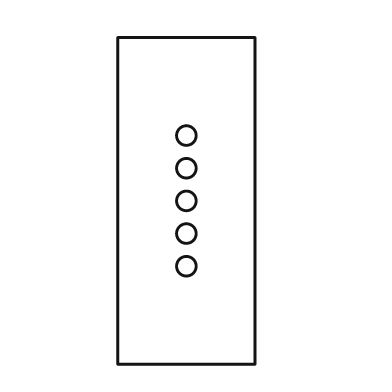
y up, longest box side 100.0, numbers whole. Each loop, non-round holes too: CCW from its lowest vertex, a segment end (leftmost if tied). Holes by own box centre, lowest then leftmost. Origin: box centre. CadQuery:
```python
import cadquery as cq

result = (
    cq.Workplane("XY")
    .moveTo(-21.0, -50.0)
    .lineTo(21.0, -50.0)
    .lineTo(21.0, 50.0)
    .lineTo(-21.0, 50.0)
    .close()
    .moveTo(0.0, -20.0)
    .circle(3.0)
    .moveTo(0.0, -10.0)
    .circle(3.0)
    .moveTo(0.0, 0.0)
    .circle(3.0)
    .moveTo(0.0, 10.0)
    .circle(3.0)
    .moveTo(0.0, 20.0)
    .circle(3.0)
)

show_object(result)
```